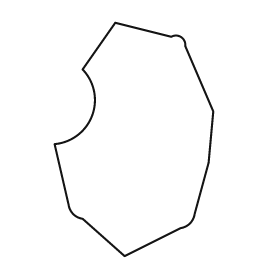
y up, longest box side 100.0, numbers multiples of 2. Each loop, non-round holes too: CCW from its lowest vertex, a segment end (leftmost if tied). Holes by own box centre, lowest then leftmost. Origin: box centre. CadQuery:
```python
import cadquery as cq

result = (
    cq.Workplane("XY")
    .moveTo(-4.0, -50.0)
    .lineTo(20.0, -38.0)
    .threePointArc((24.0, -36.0), (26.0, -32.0))
    .lineTo(32.0, -10.0)
    .lineTo(34.0, 12.0)
    .lineTo(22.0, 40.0)
    .threePointArc((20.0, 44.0), (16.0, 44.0))
    .lineTo(-8.0, 50.0)
    .lineTo(-22.0, 30.0)
    .threePointArc((-18.0, 10.0), (-34.0, -2.0))
    .lineTo(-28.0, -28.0)
    .threePointArc((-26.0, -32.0), (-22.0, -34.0))
    .close()
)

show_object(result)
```